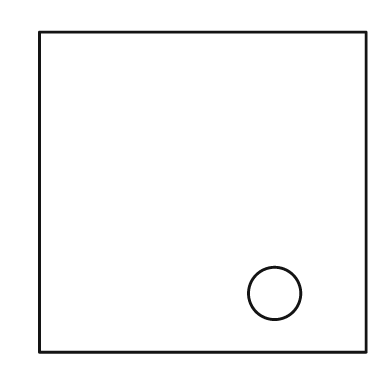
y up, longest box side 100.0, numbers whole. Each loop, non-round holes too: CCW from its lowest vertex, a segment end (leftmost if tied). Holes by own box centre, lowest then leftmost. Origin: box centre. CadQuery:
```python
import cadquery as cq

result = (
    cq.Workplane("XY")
    .moveTo(-50.0, -49.0)
    .lineTo(50.0, -49.0)
    .lineTo(50.0, 49.0)
    .lineTo(-50.0, 49.0)
    .close()
    .moveTo(22.0, -31.0)
    .circle(8.0)
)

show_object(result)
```